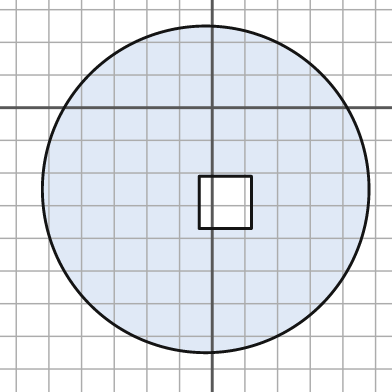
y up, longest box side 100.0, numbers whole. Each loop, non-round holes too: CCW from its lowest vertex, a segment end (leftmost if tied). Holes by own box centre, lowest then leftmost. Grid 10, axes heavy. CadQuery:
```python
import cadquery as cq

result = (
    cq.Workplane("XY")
    .moveTo(-2.0, -25.0)
    .circle(50.0)
    .moveTo(-4.0, -37.0)
    .lineTo(12.0, -37.0)
    .lineTo(12.0, -21.0)
    .lineTo(-4.0, -21.0)
    .close()
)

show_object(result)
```